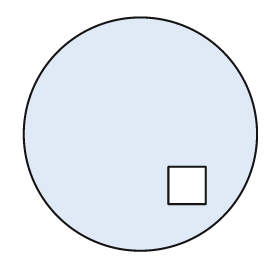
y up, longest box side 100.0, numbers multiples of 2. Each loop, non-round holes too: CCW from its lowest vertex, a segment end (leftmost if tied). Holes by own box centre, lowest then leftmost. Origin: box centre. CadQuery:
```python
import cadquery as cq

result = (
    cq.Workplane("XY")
    .moveTo(0.0, 0.0)
    .circle(50.0)
    .moveTo(12.0, -30.0)
    .lineTo(28.0, -30.0)
    .lineTo(28.0, -14.0)
    .lineTo(12.0, -14.0)
    .close()
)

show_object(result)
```